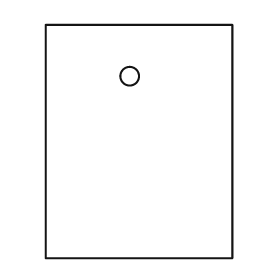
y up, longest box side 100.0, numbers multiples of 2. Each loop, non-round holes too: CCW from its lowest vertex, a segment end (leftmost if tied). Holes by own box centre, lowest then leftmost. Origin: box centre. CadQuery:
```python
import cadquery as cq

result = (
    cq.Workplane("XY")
    .moveTo(-40.0, -50.0)
    .lineTo(40.0, -50.0)
    .lineTo(40.0, 50.0)
    .lineTo(-40.0, 50.0)
    .close()
    .moveTo(-4.0, 28.0)
    .circle(4.0)
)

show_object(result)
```